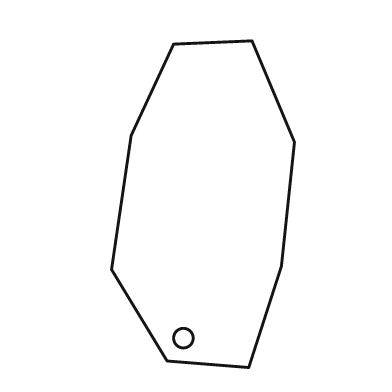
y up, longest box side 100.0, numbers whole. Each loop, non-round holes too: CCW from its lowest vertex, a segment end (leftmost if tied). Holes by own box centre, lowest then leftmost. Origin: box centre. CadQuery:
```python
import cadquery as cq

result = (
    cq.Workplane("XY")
    .moveTo(14.0, -50.0)
    .lineTo(24.0, -19.0)
    .lineTo(28.0, 19.0)
    .lineTo(15.0, 50.0)
    .lineTo(-9.0, 49.0)
    .lineTo(-22.0, 21.0)
    .lineTo(-28.0, -20.0)
    .lineTo(-11.0, -48.0)
    .close()
    .moveTo(-6.0, -41.0)
    .circle(3.0)
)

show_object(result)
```